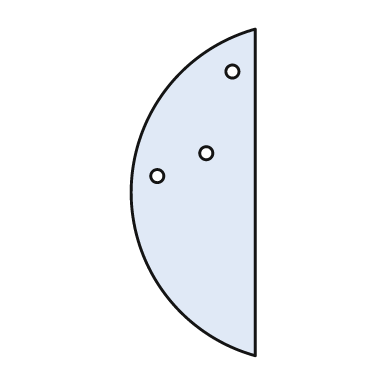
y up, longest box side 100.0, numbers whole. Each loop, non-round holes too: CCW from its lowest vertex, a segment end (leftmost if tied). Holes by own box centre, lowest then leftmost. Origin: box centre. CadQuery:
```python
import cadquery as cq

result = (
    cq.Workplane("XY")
    .moveTo(19.0, -50.0)
    .lineTo(19.0, 50.0)
    .threePointArc((-19.0, 0.0), (19.0, -50.0))
    .close()
    .moveTo(-11.0, 5.0)
    .circle(2.0)
    .moveTo(4.0, 12.0)
    .circle(2.0)
    .moveTo(12.0, 37.0)
    .circle(2.0)
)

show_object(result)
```